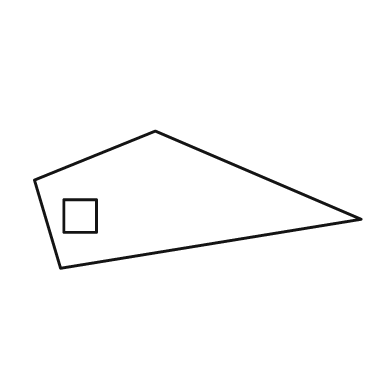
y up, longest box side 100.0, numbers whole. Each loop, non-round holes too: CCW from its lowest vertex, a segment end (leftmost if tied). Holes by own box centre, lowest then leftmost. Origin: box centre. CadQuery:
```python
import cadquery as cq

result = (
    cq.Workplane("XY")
    .moveTo(-42.0, -21.0)
    .lineTo(50.0, -6.0)
    .lineTo(-13.0, 21.0)
    .lineTo(-50.0, 6.0)
    .close()
    .moveTo(-41.0, -10.0)
    .lineTo(-31.0, -10.0)
    .lineTo(-31.0, 0.0)
    .lineTo(-41.0, 0.0)
    .close()
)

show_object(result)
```